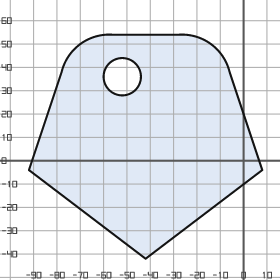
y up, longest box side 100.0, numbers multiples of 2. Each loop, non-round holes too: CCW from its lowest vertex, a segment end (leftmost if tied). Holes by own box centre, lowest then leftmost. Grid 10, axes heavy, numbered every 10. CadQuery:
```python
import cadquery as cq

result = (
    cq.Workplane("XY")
    .moveTo(-42.0, -42.0)
    .lineTo(8.0, -4.0)
    .lineTo(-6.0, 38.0)
    .threePointArc((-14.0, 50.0), (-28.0, 54.0))
    .lineTo(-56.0, 54.0)
    .threePointArc((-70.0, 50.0), (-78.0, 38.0))
    .lineTo(-92.0, -4.0)
    .close()
    .moveTo(-52.0, 36.0)
    .circle(8.0)
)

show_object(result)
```